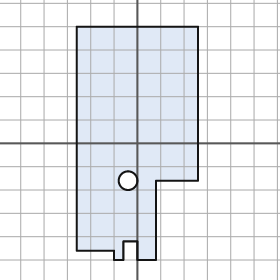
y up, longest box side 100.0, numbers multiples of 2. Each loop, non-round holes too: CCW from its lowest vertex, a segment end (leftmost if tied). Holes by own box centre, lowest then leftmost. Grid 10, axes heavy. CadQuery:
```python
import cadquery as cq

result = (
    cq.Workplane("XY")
    .moveTo(-10.0, -50.0)
    .lineTo(-6.0, -50.0)
    .lineTo(-6.0, -42.0)
    .lineTo(0.0, -42.0)
    .lineTo(0.0, -50.0)
    .lineTo(8.0, -50.0)
    .lineTo(8.0, -16.0)
    .lineTo(26.0, -16.0)
    .lineTo(26.0, 50.0)
    .lineTo(-26.0, 50.0)
    .lineTo(-26.0, -46.0)
    .lineTo(-10.0, -46.0)
    .close()
    .moveTo(-4.0, -16.0)
    .circle(4.0)
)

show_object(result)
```